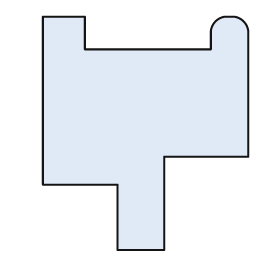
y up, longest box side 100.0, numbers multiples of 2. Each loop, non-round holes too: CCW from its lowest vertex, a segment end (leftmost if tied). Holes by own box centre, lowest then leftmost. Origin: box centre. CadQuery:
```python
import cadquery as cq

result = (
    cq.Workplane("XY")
    .moveTo(-12.0, -50.0)
    .lineTo(8.0, -50.0)
    .lineTo(8.0, -10.0)
    .lineTo(44.0, -10.0)
    .lineTo(44.0, 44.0)
    .threePointArc((42.0, 48.0), (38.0, 50.0))
    .lineTo(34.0, 50.0)
    .threePointArc((30.0, 48.0), (28.0, 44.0))
    .lineTo(28.0, 36.0)
    .lineTo(-26.0, 36.0)
    .lineTo(-26.0, 50.0)
    .lineTo(-44.0, 50.0)
    .lineTo(-44.0, -22.0)
    .lineTo(-12.0, -22.0)
    .close()
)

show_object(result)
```